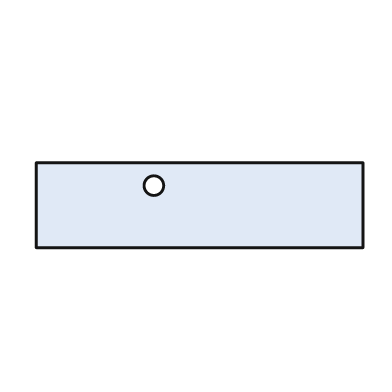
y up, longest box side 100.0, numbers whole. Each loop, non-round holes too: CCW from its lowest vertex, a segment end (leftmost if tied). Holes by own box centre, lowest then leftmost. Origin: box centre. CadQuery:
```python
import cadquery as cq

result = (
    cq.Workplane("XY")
    .moveTo(-50.0, -13.0)
    .lineTo(50.0, -13.0)
    .lineTo(50.0, 13.0)
    .lineTo(-50.0, 13.0)
    .close()
    .moveTo(-14.0, 6.0)
    .circle(3.0)
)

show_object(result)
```